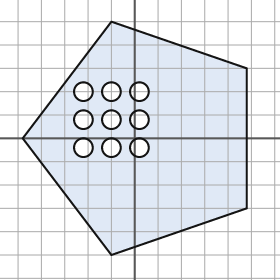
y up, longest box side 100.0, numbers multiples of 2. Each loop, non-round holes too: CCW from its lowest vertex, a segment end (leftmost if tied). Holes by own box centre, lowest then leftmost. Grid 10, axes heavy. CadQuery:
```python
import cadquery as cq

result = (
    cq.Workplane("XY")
    .moveTo(-10.0, -50.0)
    .lineTo(48.0, -30.0)
    .lineTo(48.0, 30.0)
    .lineTo(-10.0, 50.0)
    .lineTo(-48.0, 0.0)
    .close()
    .moveTo(-22.0, -4.0)
    .circle(4.0)
    .moveTo(-10.0, -4.0)
    .circle(4.0)
    .moveTo(2.0, -4.0)
    .circle(4.0)
    .moveTo(-22.0, 8.0)
    .circle(4.0)
    .moveTo(-10.0, 8.0)
    .circle(4.0)
    .moveTo(2.0, 8.0)
    .circle(4.0)
    .moveTo(-22.0, 20.0)
    .circle(4.0)
    .moveTo(-10.0, 20.0)
    .circle(4.0)
    .moveTo(2.0, 20.0)
    .circle(4.0)
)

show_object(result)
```